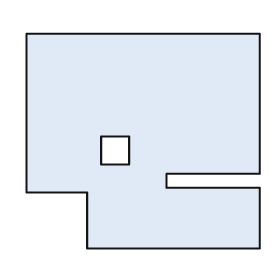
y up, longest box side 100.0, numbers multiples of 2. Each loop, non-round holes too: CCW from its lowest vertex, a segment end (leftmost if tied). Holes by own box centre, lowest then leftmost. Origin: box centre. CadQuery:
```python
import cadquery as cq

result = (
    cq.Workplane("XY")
    .moveTo(-24.0, -46.0)
    .lineTo(50.0, -46.0)
    .lineTo(50.0, -20.0)
    .lineTo(10.0, -20.0)
    .lineTo(10.0, -14.0)
    .lineTo(50.0, -14.0)
    .lineTo(50.0, 46.0)
    .lineTo(-50.0, 46.0)
    .lineTo(-50.0, -22.0)
    .lineTo(-24.0, -22.0)
    .close()
    .moveTo(-18.0, -10.0)
    .lineTo(-6.0, -10.0)
    .lineTo(-6.0, 2.0)
    .lineTo(-18.0, 2.0)
    .close()
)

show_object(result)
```